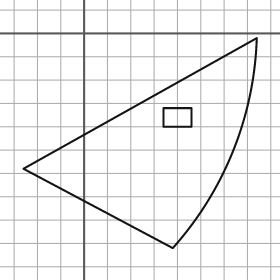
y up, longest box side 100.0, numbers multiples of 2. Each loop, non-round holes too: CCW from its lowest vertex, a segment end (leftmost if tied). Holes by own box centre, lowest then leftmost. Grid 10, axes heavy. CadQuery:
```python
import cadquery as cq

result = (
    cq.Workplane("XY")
    .moveTo(38.0, -92.0)
    .threePointArc((64.0, -50.0), (74.0, -2.0))
    .lineTo(-26.0, -58.0)
    .close()
    .moveTo(34.0, -40.0)
    .lineTo(46.0, -40.0)
    .lineTo(46.0, -32.0)
    .lineTo(34.0, -32.0)
    .close()
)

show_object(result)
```